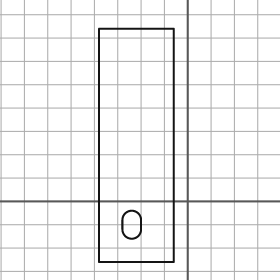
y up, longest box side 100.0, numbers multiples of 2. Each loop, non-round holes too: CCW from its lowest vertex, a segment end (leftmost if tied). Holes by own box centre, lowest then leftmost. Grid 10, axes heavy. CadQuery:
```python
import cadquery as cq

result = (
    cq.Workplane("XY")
    .moveTo(-38.0, -26.0)
    .lineTo(-6.0, -26.0)
    .lineTo(-6.0, 74.0)
    .lineTo(-38.0, 74.0)
    .close()
    .moveTo(-28.0, -12.0)
    .threePointArc((-24.0, -16.0), (-20.0, -12.0))
    .lineTo(-20.0, -8.0)
    .threePointArc((-24.0, -4.0), (-28.0, -8.0))
    .close()
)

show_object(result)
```